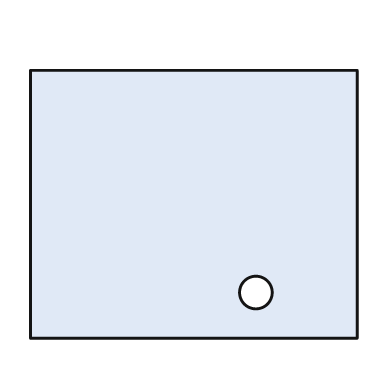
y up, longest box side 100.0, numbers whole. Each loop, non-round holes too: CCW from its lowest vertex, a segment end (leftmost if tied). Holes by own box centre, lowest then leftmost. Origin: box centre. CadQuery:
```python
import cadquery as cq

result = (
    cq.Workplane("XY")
    .moveTo(-50.0, -41.0)
    .lineTo(50.0, -41.0)
    .lineTo(50.0, 41.0)
    .lineTo(-50.0, 41.0)
    .close()
    .moveTo(19.0, -27.0)
    .circle(5.0)
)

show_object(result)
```